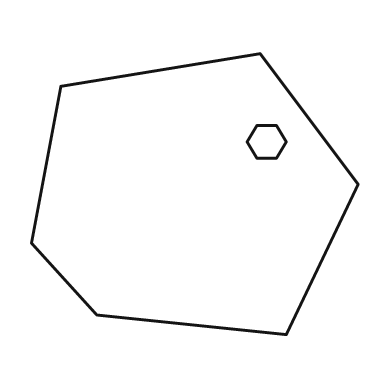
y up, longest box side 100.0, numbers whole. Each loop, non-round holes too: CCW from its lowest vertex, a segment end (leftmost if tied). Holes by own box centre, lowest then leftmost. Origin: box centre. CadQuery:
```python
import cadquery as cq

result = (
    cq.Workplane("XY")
    .moveTo(28.0, -43.0)
    .lineTo(50.0, 3.0)
    .lineTo(20.0, 43.0)
    .lineTo(-41.0, 33.0)
    .lineTo(-50.0, -15.0)
    .lineTo(-30.0, -37.0)
    .close()
    .moveTo(19.0, 11.0)
    .lineTo(25.0, 11.0)
    .lineTo(28.0, 16.0)
    .lineTo(25.0, 21.0)
    .lineTo(19.0, 21.0)
    .lineTo(16.0, 16.0)
    .close()
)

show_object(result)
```